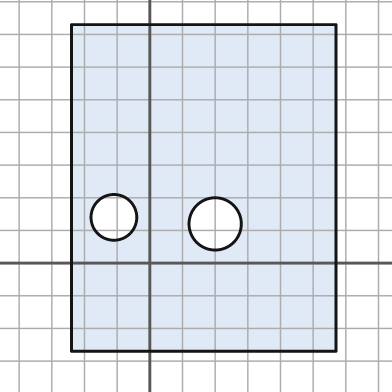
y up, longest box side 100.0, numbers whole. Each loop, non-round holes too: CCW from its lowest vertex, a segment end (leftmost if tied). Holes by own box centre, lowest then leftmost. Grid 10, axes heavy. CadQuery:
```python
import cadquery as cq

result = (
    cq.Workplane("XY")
    .moveTo(-24.0, -27.0)
    .lineTo(57.0, -27.0)
    .lineTo(57.0, 73.0)
    .lineTo(-24.0, 73.0)
    .close()
    .moveTo(20.0, 12.0)
    .circle(8.0)
    .moveTo(-11.0, 14.0)
    .circle(7.0)
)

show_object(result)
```